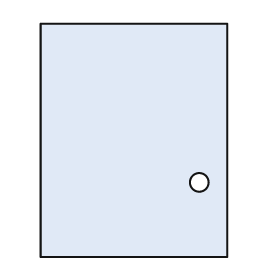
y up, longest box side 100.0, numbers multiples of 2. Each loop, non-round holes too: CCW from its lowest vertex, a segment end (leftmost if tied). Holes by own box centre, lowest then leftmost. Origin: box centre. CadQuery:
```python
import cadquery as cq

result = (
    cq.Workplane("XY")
    .moveTo(-40.0, -50.0)
    .lineTo(40.0, -50.0)
    .lineTo(40.0, 50.0)
    .lineTo(-40.0, 50.0)
    .close()
    .moveTo(28.0, -18.0)
    .circle(4.0)
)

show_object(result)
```